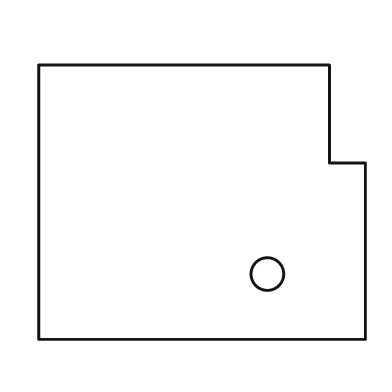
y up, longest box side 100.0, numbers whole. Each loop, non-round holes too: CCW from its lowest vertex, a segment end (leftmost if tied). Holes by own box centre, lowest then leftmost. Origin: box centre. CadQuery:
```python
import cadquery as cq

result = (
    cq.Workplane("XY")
    .moveTo(-50.0, -42.0)
    .lineTo(50.0, -42.0)
    .lineTo(50.0, 12.0)
    .lineTo(39.0, 12.0)
    .lineTo(39.0, 42.0)
    .lineTo(-50.0, 42.0)
    .close()
    .moveTo(20.0, -22.0)
    .circle(5.0)
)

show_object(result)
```